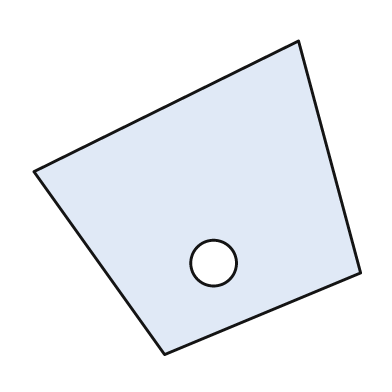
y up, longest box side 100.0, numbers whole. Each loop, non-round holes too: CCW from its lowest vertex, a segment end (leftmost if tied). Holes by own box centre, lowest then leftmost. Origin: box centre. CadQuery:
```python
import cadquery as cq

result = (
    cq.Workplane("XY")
    .moveTo(-10.0, -48.0)
    .lineTo(50.0, -23.0)
    .lineTo(31.0, 48.0)
    .lineTo(-50.0, 8.0)
    .close()
    .moveTo(5.0, -20.0)
    .circle(7.0)
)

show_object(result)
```